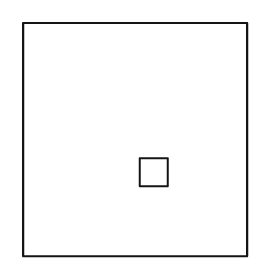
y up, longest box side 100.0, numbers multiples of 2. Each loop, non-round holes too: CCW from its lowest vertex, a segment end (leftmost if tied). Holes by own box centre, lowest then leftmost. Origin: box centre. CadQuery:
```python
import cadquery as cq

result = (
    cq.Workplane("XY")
    .moveTo(-48.0, -50.0)
    .lineTo(48.0, -50.0)
    .lineTo(48.0, 50.0)
    .lineTo(-48.0, 50.0)
    .close()
    .moveTo(2.0, -20.0)
    .lineTo(14.0, -20.0)
    .lineTo(14.0, -8.0)
    .lineTo(2.0, -8.0)
    .close()
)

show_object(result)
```